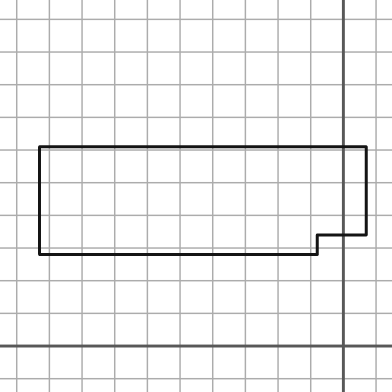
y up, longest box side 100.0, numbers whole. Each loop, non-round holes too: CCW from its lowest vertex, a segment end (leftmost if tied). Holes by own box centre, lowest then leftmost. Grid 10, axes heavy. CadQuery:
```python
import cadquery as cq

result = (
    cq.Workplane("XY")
    .moveTo(-93.0, 28.0)
    .lineTo(-8.0, 28.0)
    .lineTo(-8.0, 34.0)
    .lineTo(7.0, 34.0)
    .lineTo(7.0, 61.0)
    .lineTo(-93.0, 61.0)
    .close()
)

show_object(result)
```